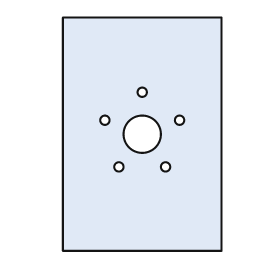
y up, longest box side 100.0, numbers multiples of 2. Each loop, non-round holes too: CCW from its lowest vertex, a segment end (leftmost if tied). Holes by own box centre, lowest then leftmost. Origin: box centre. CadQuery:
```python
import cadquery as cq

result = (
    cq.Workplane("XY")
    .moveTo(-34.0, -50.0)
    .lineTo(34.0, -50.0)
    .lineTo(34.0, 50.0)
    .lineTo(-34.0, 50.0)
    .close()
    .moveTo(-10.0, -14.0)
    .circle(2.0)
    .moveTo(10.0, -14.0)
    .circle(2.0)
    .moveTo(0.0, 0.0)
    .circle(8.0)
    .moveTo(-16.0, 6.0)
    .circle(2.0)
    .moveTo(16.0, 6.0)
    .circle(2.0)
    .moveTo(0.0, 18.0)
    .circle(2.0)
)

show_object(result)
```